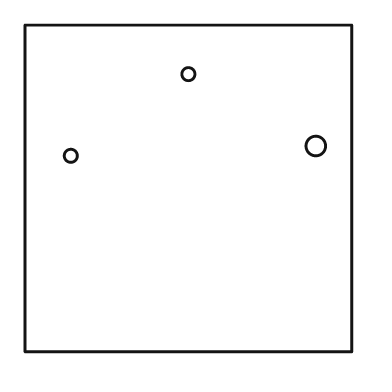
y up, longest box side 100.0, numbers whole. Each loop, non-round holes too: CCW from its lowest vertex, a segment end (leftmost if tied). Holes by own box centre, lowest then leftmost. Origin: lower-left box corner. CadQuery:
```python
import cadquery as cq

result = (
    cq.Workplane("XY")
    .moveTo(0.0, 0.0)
    .lineTo(100.0, 0.0)
    .lineTo(100.0, 100.0)
    .lineTo(0.0, 100.0)
    .close()
    .moveTo(14.0, 60.0)
    .circle(2.0)
    .moveTo(89.0, 63.0)
    .circle(3.0)
    .moveTo(50.0, 85.0)
    .circle(2.0)
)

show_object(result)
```